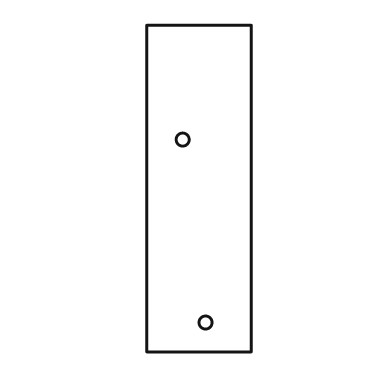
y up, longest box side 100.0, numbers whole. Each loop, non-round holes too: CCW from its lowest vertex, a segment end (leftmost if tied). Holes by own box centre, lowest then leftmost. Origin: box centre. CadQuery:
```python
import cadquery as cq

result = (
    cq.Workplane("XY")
    .moveTo(-16.0, -50.0)
    .lineTo(16.0, -50.0)
    .lineTo(16.0, 50.0)
    .lineTo(-16.0, 50.0)
    .close()
    .moveTo(2.0, -41.0)
    .circle(2.0)
    .moveTo(-5.0, 15.0)
    .circle(2.0)
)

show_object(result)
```